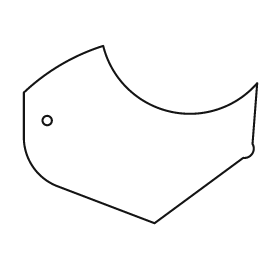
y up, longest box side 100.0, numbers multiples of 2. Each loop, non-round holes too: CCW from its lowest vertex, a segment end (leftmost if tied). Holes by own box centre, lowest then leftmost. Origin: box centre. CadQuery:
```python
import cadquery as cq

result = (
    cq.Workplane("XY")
    .moveTo(6.0, -38.0)
    .lineTo(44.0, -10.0)
    .threePointArc((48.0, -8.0), (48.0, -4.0))
    .lineTo(50.0, 22.0)
    .threePointArc((12.0, 10.0), (-16.0, 38.0))
    .threePointArc((-34.0, 30.0), (-50.0, 18.0))
    .lineTo(-50.0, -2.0)
    .threePointArc((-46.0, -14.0), (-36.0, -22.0))
    .close()
    .moveTo(-40.0, 6.0)
    .circle(2.0)
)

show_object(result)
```